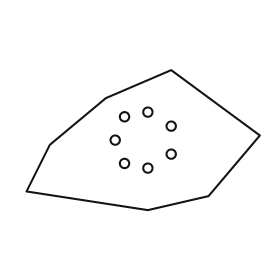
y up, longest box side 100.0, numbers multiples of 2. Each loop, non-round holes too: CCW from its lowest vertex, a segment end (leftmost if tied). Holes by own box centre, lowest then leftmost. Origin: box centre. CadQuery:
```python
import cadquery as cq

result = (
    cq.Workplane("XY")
    .moveTo(2.0, -30.0)
    .lineTo(28.0, -24.0)
    .lineTo(50.0, 2.0)
    .lineTo(12.0, 30.0)
    .lineTo(-16.0, 18.0)
    .lineTo(-40.0, -2.0)
    .lineTo(-50.0, -22.0)
    .close()
    .moveTo(2.0, -12.0)
    .circle(2.0)
    .moveTo(-8.0, -10.0)
    .circle(2.0)
    .moveTo(12.0, -6.0)
    .circle(2.0)
    .moveTo(-12.0, 0.0)
    .circle(2.0)
    .moveTo(12.0, 6.0)
    .circle(2.0)
    .moveTo(-8.0, 10.0)
    .circle(2.0)
    .moveTo(2.0, 12.0)
    .circle(2.0)
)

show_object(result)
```